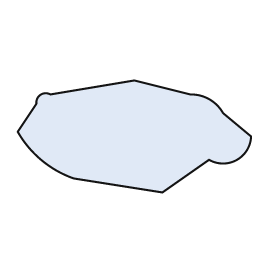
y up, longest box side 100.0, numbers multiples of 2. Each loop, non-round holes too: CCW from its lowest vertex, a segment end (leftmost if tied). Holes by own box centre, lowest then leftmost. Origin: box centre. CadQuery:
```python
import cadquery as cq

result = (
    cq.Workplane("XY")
    .moveTo(12.0, -24.0)
    .lineTo(32.0, -10.0)
    .threePointArc((44.0, -10.0), (50.0, 0.0))
    .lineTo(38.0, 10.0)
    .threePointArc((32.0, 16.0), (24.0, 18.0))
    .lineTo(0.0, 24.0)
    .lineTo(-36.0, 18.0)
    .threePointArc((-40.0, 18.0), (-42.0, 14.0))
    .lineTo(-50.0, 2.0)
    .threePointArc((-40.0, -10.0), (-26.0, -18.0))
    .close()
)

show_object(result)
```